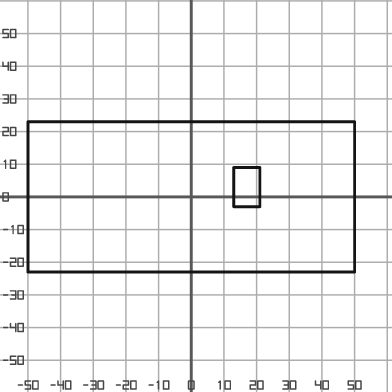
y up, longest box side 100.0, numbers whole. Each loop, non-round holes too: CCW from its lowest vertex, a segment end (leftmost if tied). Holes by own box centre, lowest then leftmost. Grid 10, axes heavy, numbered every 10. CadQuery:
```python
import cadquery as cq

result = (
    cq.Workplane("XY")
    .moveTo(-50.0, -23.0)
    .lineTo(50.0, -23.0)
    .lineTo(50.0, 23.0)
    .lineTo(-50.0, 23.0)
    .close()
    .moveTo(13.0, -3.0)
    .lineTo(21.0, -3.0)
    .lineTo(21.0, 9.0)
    .lineTo(13.0, 9.0)
    .close()
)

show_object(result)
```